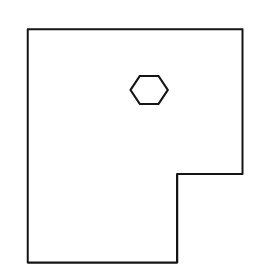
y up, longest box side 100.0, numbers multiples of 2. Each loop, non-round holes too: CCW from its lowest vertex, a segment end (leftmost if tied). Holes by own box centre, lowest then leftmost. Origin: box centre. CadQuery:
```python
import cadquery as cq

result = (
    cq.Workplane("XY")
    .moveTo(-46.0, -50.0)
    .lineTo(18.0, -50.0)
    .lineTo(18.0, -12.0)
    .lineTo(46.0, -12.0)
    .lineTo(46.0, 50.0)
    .lineTo(-46.0, 50.0)
    .close()
    .moveTo(2.0, 18.0)
    .lineTo(10.0, 18.0)
    .lineTo(14.0, 24.0)
    .lineTo(10.0, 30.0)
    .lineTo(2.0, 30.0)
    .lineTo(-2.0, 24.0)
    .close()
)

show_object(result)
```